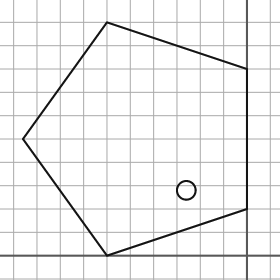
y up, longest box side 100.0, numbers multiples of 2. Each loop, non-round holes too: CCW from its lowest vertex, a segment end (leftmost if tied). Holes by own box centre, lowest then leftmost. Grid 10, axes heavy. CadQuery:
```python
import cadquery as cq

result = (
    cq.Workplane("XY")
    .moveTo(-60.0, 0.0)
    .lineTo(0.0, 20.0)
    .lineTo(0.0, 80.0)
    .lineTo(-60.0, 100.0)
    .lineTo(-96.0, 50.0)
    .close()
    .moveTo(-26.0, 28.0)
    .circle(4.0)
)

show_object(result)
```